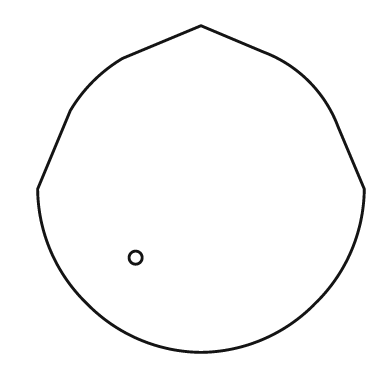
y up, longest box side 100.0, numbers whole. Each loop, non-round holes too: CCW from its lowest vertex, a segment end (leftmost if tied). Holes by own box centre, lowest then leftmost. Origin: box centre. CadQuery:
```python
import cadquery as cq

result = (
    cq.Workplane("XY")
    .moveTo(0.0, -50.0)
    .threePointArc((19.0, -46.0), (35.0, -35.0))
    .threePointArc((46.0, -19.0), (50.0, 0.0))
    .lineTo(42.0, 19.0)
    .threePointArc((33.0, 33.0), (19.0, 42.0))
    .lineTo(0.0, 50.0)
    .lineTo(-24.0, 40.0)
    .threePointArc((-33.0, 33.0), (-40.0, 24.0))
    .lineTo(-50.0, 0.0)
    .threePointArc((-46.0, -19.0), (-35.0, -35.0))
    .threePointArc((-19.0, -46.0), (0.0, -50.0))
    .close()
    .moveTo(-20.0, -21.0)
    .circle(2.0)
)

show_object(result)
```